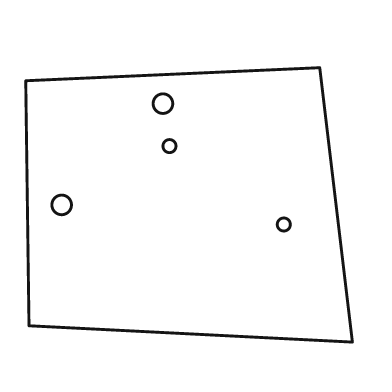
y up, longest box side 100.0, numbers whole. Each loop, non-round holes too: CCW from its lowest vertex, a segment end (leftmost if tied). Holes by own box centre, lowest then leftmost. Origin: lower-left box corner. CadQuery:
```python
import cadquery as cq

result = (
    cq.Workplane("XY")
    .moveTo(100.0, 0.0)
    .lineTo(90.0, 84.0)
    .lineTo(0.0, 80.0)
    .lineTo(1.0, 5.0)
    .close()
    .moveTo(79.0, 36.0)
    .circle(2.0)
    .moveTo(11.0, 42.0)
    .circle(3.0)
    .moveTo(44.0, 60.0)
    .circle(2.0)
    .moveTo(42.0, 73.0)
    .circle(3.0)
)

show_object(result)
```